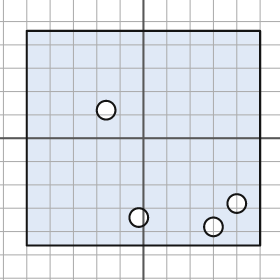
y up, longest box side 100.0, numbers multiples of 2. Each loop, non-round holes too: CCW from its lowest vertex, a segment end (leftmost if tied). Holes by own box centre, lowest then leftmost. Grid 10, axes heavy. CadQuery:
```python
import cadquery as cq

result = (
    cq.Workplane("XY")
    .moveTo(-50.0, -46.0)
    .lineTo(50.0, -46.0)
    .lineTo(50.0, 46.0)
    .lineTo(-50.0, 46.0)
    .close()
    .moveTo(30.0, -38.0)
    .circle(4.0)
    .moveTo(-2.0, -34.0)
    .circle(4.0)
    .moveTo(40.0, -28.0)
    .circle(4.0)
    .moveTo(-16.0, 12.0)
    .circle(4.0)
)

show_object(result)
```